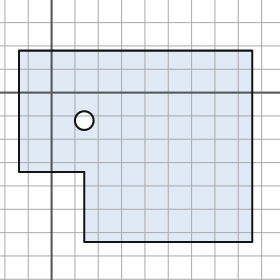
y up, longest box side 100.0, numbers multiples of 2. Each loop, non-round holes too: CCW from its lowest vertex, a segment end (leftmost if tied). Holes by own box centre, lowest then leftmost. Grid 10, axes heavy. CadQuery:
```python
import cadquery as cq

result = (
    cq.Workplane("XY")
    .moveTo(14.0, -64.0)
    .lineTo(86.0, -64.0)
    .lineTo(86.0, 18.0)
    .lineTo(-14.0, 18.0)
    .lineTo(-14.0, -34.0)
    .lineTo(14.0, -34.0)
    .close()
    .moveTo(14.0, -12.0)
    .circle(4.0)
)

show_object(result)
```